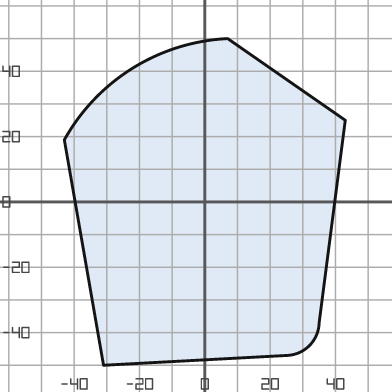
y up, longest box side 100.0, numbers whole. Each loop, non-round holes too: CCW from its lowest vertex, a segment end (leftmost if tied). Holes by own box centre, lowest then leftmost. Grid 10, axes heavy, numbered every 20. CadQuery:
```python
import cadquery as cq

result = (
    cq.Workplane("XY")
    .moveTo(-31.0, -50.0)
    .lineTo(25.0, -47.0)
    .threePointArc((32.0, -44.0), (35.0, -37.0))
    .lineTo(43.0, 25.0)
    .lineTo(7.0, 50.0)
    .threePointArc((-22.0, 41.0), (-43.0, 19.0))
    .close()
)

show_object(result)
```